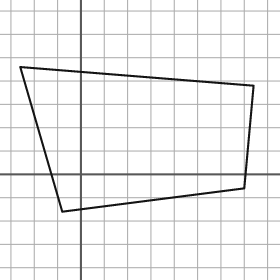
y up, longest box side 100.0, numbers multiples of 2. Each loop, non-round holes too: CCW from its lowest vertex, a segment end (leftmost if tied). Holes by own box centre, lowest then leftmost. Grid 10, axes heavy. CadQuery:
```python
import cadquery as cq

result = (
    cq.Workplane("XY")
    .moveTo(-8.0, -16.0)
    .lineTo(70.0, -6.0)
    .lineTo(74.0, 38.0)
    .lineTo(-26.0, 46.0)
    .close()
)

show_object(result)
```